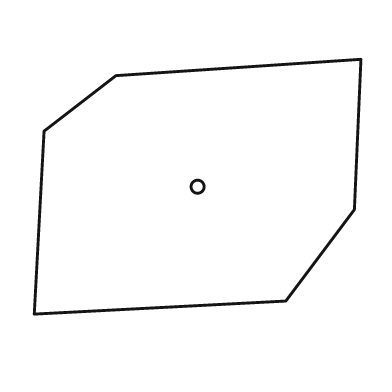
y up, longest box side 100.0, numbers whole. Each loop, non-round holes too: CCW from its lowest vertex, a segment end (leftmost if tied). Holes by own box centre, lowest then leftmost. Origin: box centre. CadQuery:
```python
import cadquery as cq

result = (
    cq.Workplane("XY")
    .moveTo(-50.0, -39.0)
    .lineTo(27.0, -35.0)
    .lineTo(48.0, -7.0)
    .lineTo(50.0, 39.0)
    .lineTo(-25.0, 34.0)
    .lineTo(-47.0, 17.0)
    .close()
    .moveTo(0.0, 0.0)
    .circle(2.0)
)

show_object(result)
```